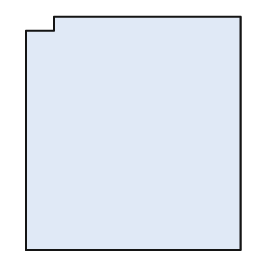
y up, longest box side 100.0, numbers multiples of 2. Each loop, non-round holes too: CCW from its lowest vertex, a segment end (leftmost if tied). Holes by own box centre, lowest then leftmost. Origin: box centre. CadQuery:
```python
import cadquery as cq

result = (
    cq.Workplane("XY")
    .moveTo(-46.0, -50.0)
    .lineTo(46.0, -50.0)
    .lineTo(46.0, 50.0)
    .lineTo(-34.0, 50.0)
    .lineTo(-34.0, 44.0)
    .lineTo(-46.0, 44.0)
    .close()
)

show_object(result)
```